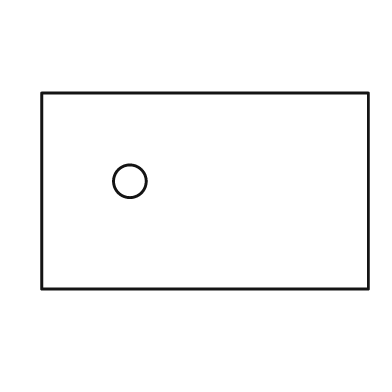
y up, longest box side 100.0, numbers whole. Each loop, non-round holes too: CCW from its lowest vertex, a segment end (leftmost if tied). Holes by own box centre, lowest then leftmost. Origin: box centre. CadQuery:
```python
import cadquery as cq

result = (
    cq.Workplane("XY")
    .moveTo(-50.0, -30.0)
    .lineTo(50.0, -30.0)
    .lineTo(50.0, 30.0)
    .lineTo(-50.0, 30.0)
    .close()
    .moveTo(-23.0, 3.0)
    .circle(5.0)
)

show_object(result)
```